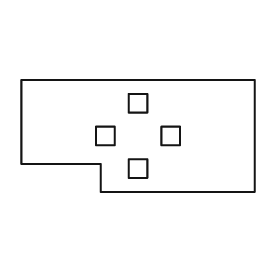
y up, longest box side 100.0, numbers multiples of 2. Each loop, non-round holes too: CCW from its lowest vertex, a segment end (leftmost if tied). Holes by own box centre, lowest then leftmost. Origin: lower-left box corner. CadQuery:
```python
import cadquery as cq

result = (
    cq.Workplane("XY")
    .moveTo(34.0, 0.0)
    .lineTo(100.0, 0.0)
    .lineTo(100.0, 48.0)
    .lineTo(0.0, 48.0)
    .lineTo(0.0, 12.0)
    .lineTo(34.0, 12.0)
    .close()
    .moveTo(46.0, 6.0)
    .lineTo(54.0, 6.0)
    .lineTo(54.0, 14.0)
    .lineTo(46.0, 14.0)
    .close()
    .moveTo(32.0, 20.0)
    .lineTo(40.0, 20.0)
    .lineTo(40.0, 28.0)
    .lineTo(32.0, 28.0)
    .close()
    .moveTo(60.0, 20.0)
    .lineTo(68.0, 20.0)
    .lineTo(68.0, 28.0)
    .lineTo(60.0, 28.0)
    .close()
    .moveTo(46.0, 34.0)
    .lineTo(54.0, 34.0)
    .lineTo(54.0, 42.0)
    .lineTo(46.0, 42.0)
    .close()
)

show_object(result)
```